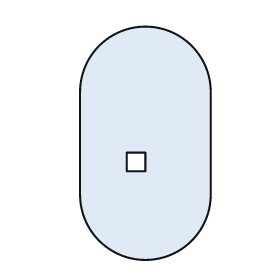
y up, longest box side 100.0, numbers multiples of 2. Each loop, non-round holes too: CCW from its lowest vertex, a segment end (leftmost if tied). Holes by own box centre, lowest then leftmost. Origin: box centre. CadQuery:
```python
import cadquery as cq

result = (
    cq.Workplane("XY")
    .moveTo(-28.0, -22.0)
    .threePointArc((0.0, -50.0), (28.0, -22.0))
    .lineTo(28.0, 22.0)
    .threePointArc((0.0, 50.0), (-28.0, 22.0))
    .close()
    .moveTo(-8.0, -12.0)
    .lineTo(0.0, -12.0)
    .lineTo(0.0, -4.0)
    .lineTo(-8.0, -4.0)
    .close()
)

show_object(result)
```